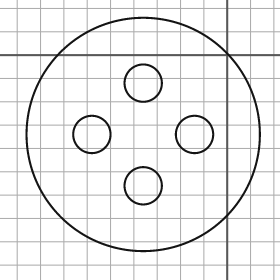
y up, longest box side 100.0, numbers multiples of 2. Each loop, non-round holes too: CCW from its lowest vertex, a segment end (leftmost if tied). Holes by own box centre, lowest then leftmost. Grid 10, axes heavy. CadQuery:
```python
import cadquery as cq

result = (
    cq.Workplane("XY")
    .moveTo(-36.0, -34.0)
    .circle(50.0)
    .moveTo(-36.0, -56.0)
    .circle(8.0)
    .moveTo(-58.0, -34.0)
    .circle(8.0)
    .moveTo(-14.0, -34.0)
    .circle(8.0)
    .moveTo(-36.0, -12.0)
    .circle(8.0)
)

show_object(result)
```